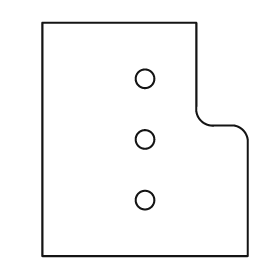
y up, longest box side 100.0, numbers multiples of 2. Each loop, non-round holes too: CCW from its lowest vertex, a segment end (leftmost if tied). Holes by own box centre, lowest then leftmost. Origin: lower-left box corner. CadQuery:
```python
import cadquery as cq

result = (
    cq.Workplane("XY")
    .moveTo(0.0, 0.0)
    .lineTo(88.0, 0.0)
    .lineTo(88.0, 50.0)
    .threePointArc((86.0, 54.0), (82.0, 56.0))
    .lineTo(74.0, 56.0)
    .threePointArc((68.0, 58.0), (66.0, 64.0))
    .lineTo(66.0, 100.0)
    .lineTo(0.0, 100.0)
    .close()
    .moveTo(44.0, 24.0)
    .circle(4.0)
    .moveTo(44.0, 50.0)
    .circle(4.0)
    .moveTo(44.0, 76.0)
    .circle(4.0)
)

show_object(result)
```